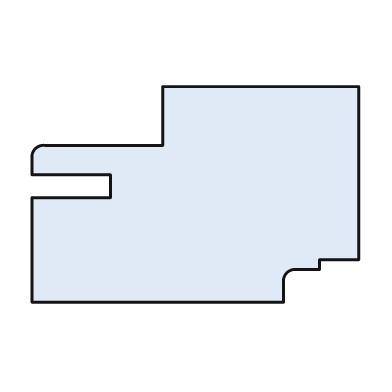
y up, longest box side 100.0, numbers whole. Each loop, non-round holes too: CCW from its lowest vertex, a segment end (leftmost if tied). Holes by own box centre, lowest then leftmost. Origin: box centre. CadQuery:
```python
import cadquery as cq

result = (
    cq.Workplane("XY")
    .moveTo(-50.0, -33.0)
    .lineTo(27.0, -33.0)
    .lineTo(27.0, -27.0)
    .threePointArc((28.0, -24.0), (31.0, -23.0))
    .lineTo(38.0, -23.0)
    .lineTo(38.0, -20.0)
    .lineTo(50.0, -20.0)
    .lineTo(50.0, 33.0)
    .lineTo(-10.0, 33.0)
    .lineTo(-10.0, 15.0)
    .lineTo(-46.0, 15.0)
    .threePointArc((-49.0, 14.0), (-50.0, 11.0))
    .lineTo(-50.0, 6.0)
    .lineTo(-26.0, 6.0)
    .lineTo(-26.0, -1.0)
    .lineTo(-50.0, -1.0)
    .close()
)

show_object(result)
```